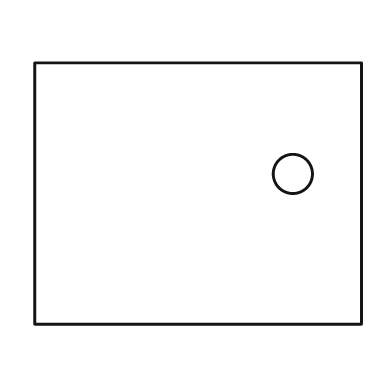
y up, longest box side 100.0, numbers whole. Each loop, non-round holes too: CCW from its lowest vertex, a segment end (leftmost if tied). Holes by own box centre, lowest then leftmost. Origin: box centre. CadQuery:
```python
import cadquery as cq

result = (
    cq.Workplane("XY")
    .moveTo(-50.0, -40.0)
    .lineTo(50.0, -40.0)
    .lineTo(50.0, 40.0)
    .lineTo(-50.0, 40.0)
    .close()
    .moveTo(29.0, 6.0)
    .circle(6.0)
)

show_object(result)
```